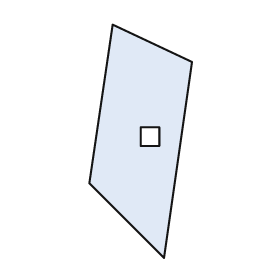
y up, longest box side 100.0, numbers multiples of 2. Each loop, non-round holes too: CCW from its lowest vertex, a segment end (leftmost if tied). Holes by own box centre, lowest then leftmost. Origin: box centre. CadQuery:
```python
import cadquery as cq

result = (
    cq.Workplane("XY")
    .moveTo(10.0, -50.0)
    .lineTo(22.0, 34.0)
    .lineTo(-12.0, 50.0)
    .lineTo(-22.0, -18.0)
    .close()
    .moveTo(0.0, -2.0)
    .lineTo(8.0, -2.0)
    .lineTo(8.0, 6.0)
    .lineTo(0.0, 6.0)
    .close()
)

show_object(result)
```